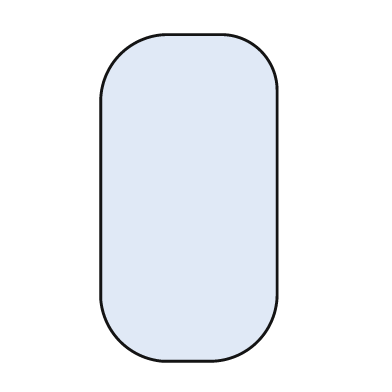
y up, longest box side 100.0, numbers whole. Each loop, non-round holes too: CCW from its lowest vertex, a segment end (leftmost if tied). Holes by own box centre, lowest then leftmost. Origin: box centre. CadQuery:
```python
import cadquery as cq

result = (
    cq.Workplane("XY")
    .moveTo(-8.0, -50.0)
    .lineTo(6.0, -50.0)
    .threePointArc((21.0, -44.0), (27.0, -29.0))
    .lineTo(27.0, 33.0)
    .threePointArc((22.0, 45.0), (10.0, 50.0))
    .lineTo(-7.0, 50.0)
    .threePointArc((-21.0, 44.0), (-27.0, 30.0))
    .lineTo(-27.0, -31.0)
    .threePointArc((-21.0, -44.0), (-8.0, -50.0))
    .close()
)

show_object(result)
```